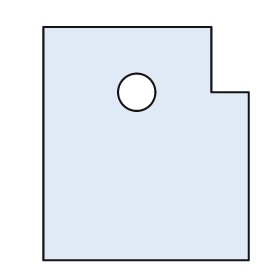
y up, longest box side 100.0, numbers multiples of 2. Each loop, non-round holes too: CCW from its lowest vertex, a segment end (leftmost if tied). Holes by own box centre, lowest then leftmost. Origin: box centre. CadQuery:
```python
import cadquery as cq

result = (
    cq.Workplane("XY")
    .moveTo(-44.0, -50.0)
    .lineTo(44.0, -50.0)
    .lineTo(44.0, 22.0)
    .lineTo(28.0, 22.0)
    .lineTo(28.0, 50.0)
    .lineTo(-44.0, 50.0)
    .close()
    .moveTo(-4.0, 22.0)
    .circle(8.0)
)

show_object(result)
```